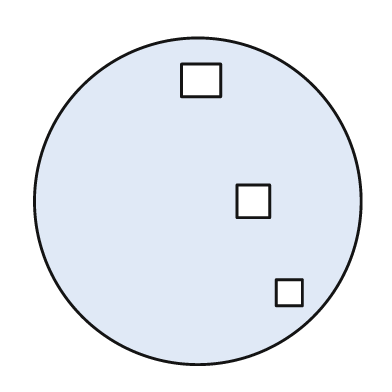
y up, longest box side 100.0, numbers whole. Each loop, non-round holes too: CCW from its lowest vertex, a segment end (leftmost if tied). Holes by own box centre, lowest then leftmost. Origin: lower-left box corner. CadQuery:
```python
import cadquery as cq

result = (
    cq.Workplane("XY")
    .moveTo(50.0, 50.0)
    .circle(50.0)
    .moveTo(74.0, 18.0)
    .lineTo(82.0, 18.0)
    .lineTo(82.0, 26.0)
    .lineTo(74.0, 26.0)
    .close()
    .moveTo(62.0, 45.0)
    .lineTo(72.0, 45.0)
    .lineTo(72.0, 55.0)
    .lineTo(62.0, 55.0)
    .close()
    .moveTo(45.0, 82.0)
    .lineTo(57.0, 82.0)
    .lineTo(57.0, 92.0)
    .lineTo(45.0, 92.0)
    .close()
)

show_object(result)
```